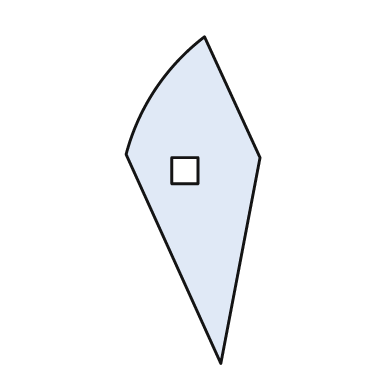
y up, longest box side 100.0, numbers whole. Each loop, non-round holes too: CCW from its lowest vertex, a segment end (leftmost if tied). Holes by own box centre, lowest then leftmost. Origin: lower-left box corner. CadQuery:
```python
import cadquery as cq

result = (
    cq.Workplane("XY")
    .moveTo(29.0, 0.0)
    .lineTo(41.0, 63.0)
    .lineTo(24.0, 100.0)
    .threePointArc((9.0, 84.0), (0.0, 64.0))
    .close()
    .moveTo(14.0, 55.0)
    .lineTo(22.0, 55.0)
    .lineTo(22.0, 63.0)
    .lineTo(14.0, 63.0)
    .close()
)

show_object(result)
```